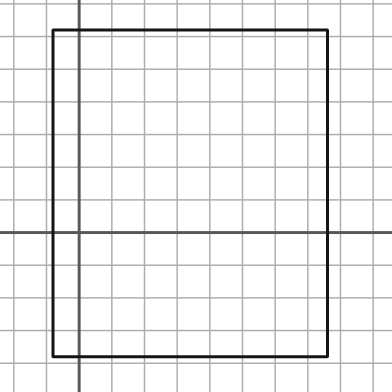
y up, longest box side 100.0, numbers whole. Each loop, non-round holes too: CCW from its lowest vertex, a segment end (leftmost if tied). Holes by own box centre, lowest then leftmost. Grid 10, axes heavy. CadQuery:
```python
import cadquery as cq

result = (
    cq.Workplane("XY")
    .moveTo(-8.0, -38.0)
    .lineTo(76.0, -38.0)
    .lineTo(76.0, 62.0)
    .lineTo(-8.0, 62.0)
    .close()
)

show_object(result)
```